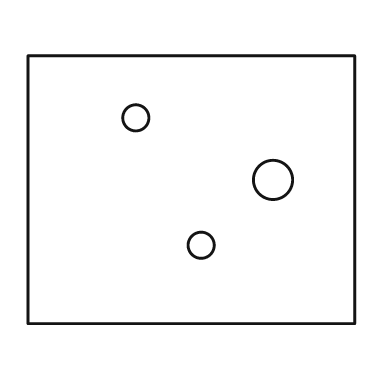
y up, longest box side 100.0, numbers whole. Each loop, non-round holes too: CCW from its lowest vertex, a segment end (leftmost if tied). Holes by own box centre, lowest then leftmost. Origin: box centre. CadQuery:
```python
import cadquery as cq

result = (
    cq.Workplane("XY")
    .moveTo(-50.0, -41.0)
    .lineTo(50.0, -41.0)
    .lineTo(50.0, 41.0)
    .lineTo(-50.0, 41.0)
    .close()
    .moveTo(3.0, -17.0)
    .circle(4.0)
    .moveTo(25.0, 3.0)
    .circle(6.0)
    .moveTo(-17.0, 22.0)
    .circle(4.0)
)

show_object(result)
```